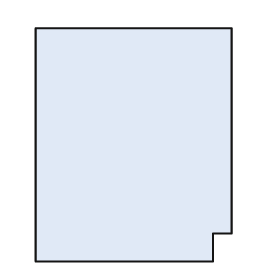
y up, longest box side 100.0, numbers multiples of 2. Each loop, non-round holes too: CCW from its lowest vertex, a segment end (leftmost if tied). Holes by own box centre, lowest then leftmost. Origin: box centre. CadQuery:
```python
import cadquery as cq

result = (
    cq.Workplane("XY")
    .moveTo(-42.0, -50.0)
    .lineTo(34.0, -50.0)
    .lineTo(34.0, -38.0)
    .lineTo(42.0, -38.0)
    .lineTo(42.0, 50.0)
    .lineTo(-42.0, 50.0)
    .close()
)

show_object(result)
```